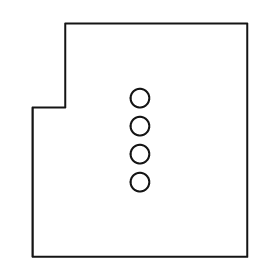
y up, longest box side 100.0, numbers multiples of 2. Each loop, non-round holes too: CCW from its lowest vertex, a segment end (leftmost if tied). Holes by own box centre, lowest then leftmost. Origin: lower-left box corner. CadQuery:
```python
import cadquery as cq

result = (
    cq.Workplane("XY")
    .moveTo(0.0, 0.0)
    .lineTo(92.0, 0.0)
    .lineTo(92.0, 100.0)
    .lineTo(14.0, 100.0)
    .lineTo(14.0, 64.0)
    .lineTo(0.0, 64.0)
    .close()
    .moveTo(46.0, 32.0)
    .circle(4.0)
    .moveTo(46.0, 44.0)
    .circle(4.0)
    .moveTo(46.0, 56.0)
    .circle(4.0)
    .moveTo(46.0, 68.0)
    .circle(4.0)
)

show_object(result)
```